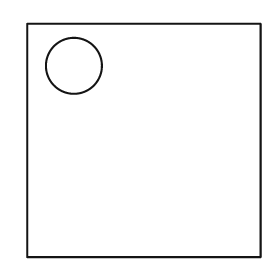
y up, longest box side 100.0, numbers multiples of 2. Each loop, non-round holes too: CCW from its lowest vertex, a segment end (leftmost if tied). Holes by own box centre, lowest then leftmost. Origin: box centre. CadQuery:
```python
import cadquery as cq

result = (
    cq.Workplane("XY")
    .moveTo(-50.0, -50.0)
    .lineTo(50.0, -50.0)
    .lineTo(50.0, 50.0)
    .lineTo(-50.0, 50.0)
    .close()
    .moveTo(-30.0, 32.0)
    .circle(12.0)
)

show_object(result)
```